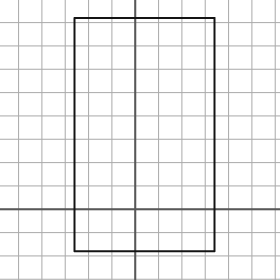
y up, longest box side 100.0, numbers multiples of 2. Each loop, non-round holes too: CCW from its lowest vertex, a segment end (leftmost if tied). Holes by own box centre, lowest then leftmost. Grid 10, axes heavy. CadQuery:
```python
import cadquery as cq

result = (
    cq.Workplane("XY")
    .moveTo(-26.0, -18.0)
    .lineTo(34.0, -18.0)
    .lineTo(34.0, 82.0)
    .lineTo(-26.0, 82.0)
    .close()
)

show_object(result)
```